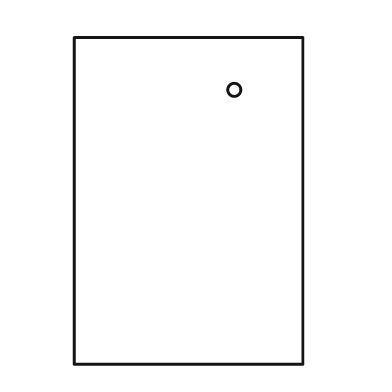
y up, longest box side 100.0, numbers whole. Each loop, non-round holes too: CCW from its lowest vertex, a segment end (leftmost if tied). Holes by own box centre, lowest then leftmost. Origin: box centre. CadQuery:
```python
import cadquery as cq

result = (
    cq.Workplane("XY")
    .moveTo(-35.0, -50.0)
    .lineTo(35.0, -50.0)
    .lineTo(35.0, 50.0)
    .lineTo(-35.0, 50.0)
    .close()
    .moveTo(14.0, 34.0)
    .circle(2.0)
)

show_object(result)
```